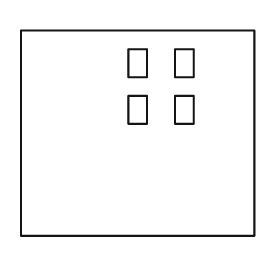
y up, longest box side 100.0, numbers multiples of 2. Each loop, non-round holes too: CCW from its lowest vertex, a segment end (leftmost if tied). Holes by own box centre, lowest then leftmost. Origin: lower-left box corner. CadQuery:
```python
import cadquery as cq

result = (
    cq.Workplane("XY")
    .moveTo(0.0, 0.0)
    .lineTo(100.0, 0.0)
    .lineTo(100.0, 88.0)
    .lineTo(0.0, 88.0)
    .close()
    .moveTo(46.0, 48.0)
    .lineTo(54.0, 48.0)
    .lineTo(54.0, 60.0)
    .lineTo(46.0, 60.0)
    .close()
    .moveTo(66.0, 48.0)
    .lineTo(74.0, 48.0)
    .lineTo(74.0, 60.0)
    .lineTo(66.0, 60.0)
    .close()
    .moveTo(46.0, 68.0)
    .lineTo(54.0, 68.0)
    .lineTo(54.0, 80.0)
    .lineTo(46.0, 80.0)
    .close()
    .moveTo(66.0, 68.0)
    .lineTo(74.0, 68.0)
    .lineTo(74.0, 80.0)
    .lineTo(66.0, 80.0)
    .close()
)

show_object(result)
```